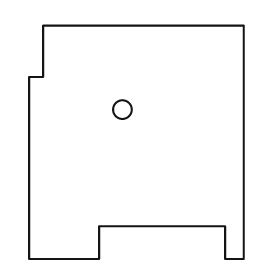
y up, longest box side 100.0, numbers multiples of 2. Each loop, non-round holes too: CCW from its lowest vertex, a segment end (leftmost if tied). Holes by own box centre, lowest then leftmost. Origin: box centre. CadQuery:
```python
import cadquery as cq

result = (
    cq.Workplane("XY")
    .moveTo(-46.0, -50.0)
    .lineTo(-16.0, -50.0)
    .lineTo(-16.0, -36.0)
    .lineTo(38.0, -36.0)
    .lineTo(38.0, -50.0)
    .lineTo(46.0, -50.0)
    .lineTo(46.0, 50.0)
    .lineTo(-40.0, 50.0)
    .lineTo(-40.0, 28.0)
    .lineTo(-46.0, 28.0)
    .close()
    .moveTo(-6.0, 14.0)
    .circle(4.0)
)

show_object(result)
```